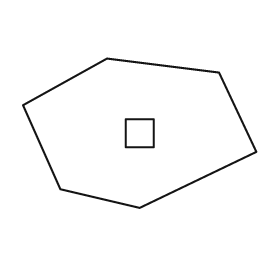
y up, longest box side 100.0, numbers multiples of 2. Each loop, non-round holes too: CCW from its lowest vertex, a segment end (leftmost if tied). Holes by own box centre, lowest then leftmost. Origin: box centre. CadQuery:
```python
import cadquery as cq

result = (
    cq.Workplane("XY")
    .moveTo(0.0, -32.0)
    .lineTo(50.0, -8.0)
    .lineTo(34.0, 26.0)
    .lineTo(-14.0, 32.0)
    .lineTo(-50.0, 12.0)
    .lineTo(-34.0, -24.0)
    .close()
    .moveTo(-6.0, -6.0)
    .lineTo(6.0, -6.0)
    .lineTo(6.0, 6.0)
    .lineTo(-6.0, 6.0)
    .close()
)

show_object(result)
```